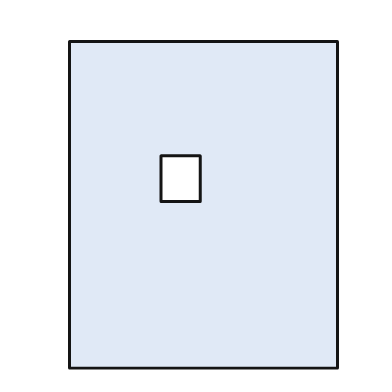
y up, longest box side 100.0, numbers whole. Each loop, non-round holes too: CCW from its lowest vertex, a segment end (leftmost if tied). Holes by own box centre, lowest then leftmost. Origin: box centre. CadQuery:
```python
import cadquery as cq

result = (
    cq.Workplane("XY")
    .moveTo(-41.0, -50.0)
    .lineTo(41.0, -50.0)
    .lineTo(41.0, 50.0)
    .lineTo(-41.0, 50.0)
    .close()
    .moveTo(-13.0, 1.0)
    .lineTo(-1.0, 1.0)
    .lineTo(-1.0, 15.0)
    .lineTo(-13.0, 15.0)
    .close()
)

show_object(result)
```